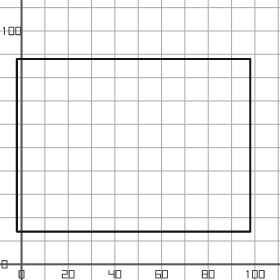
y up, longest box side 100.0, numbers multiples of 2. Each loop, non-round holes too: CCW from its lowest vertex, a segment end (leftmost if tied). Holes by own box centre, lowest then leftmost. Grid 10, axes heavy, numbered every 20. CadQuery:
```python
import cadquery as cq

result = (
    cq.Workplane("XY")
    .moveTo(-2.0, 14.0)
    .lineTo(98.0, 14.0)
    .lineTo(98.0, 88.0)
    .lineTo(-2.0, 88.0)
    .close()
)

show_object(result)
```